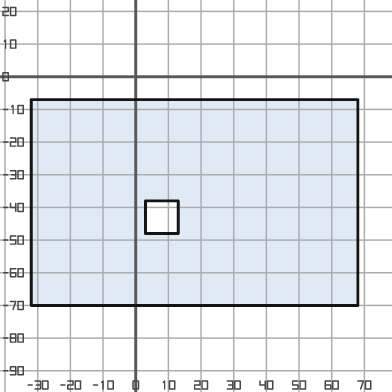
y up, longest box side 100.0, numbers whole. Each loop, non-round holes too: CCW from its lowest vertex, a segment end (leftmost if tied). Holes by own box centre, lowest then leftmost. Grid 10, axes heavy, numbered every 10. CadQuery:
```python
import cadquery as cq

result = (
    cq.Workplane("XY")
    .moveTo(-32.0, -70.0)
    .lineTo(68.0, -70.0)
    .lineTo(68.0, -7.0)
    .lineTo(-32.0, -7.0)
    .close()
    .moveTo(3.0, -48.0)
    .lineTo(13.0, -48.0)
    .lineTo(13.0, -38.0)
    .lineTo(3.0, -38.0)
    .close()
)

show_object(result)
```